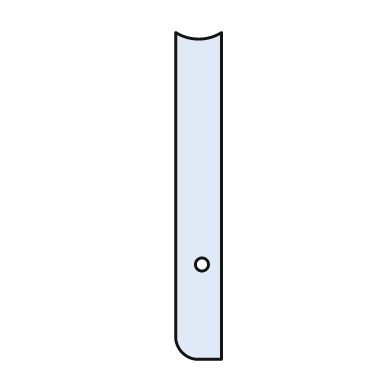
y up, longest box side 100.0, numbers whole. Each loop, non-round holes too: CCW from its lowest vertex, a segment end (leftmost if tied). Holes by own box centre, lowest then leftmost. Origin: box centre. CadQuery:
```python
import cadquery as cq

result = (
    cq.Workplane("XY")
    .moveTo(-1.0, -50.0)
    .lineTo(7.0, -50.0)
    .lineTo(7.0, 50.0)
    .threePointArc((0.0, 48.0), (-7.0, 50.0))
    .lineTo(-7.0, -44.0)
    .threePointArc((-5.0, -48.0), (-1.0, -50.0))
    .close()
    .moveTo(1.0, -21.0)
    .circle(2.0)
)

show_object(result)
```